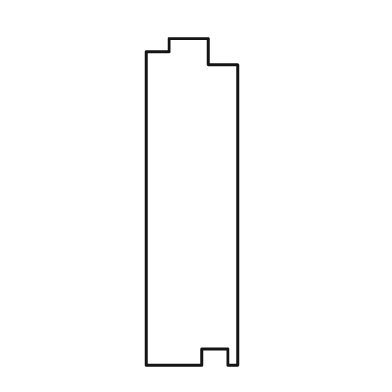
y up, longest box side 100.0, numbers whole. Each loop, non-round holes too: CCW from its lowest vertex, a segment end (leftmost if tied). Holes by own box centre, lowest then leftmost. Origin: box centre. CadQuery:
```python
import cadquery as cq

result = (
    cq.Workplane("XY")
    .moveTo(-14.0, -50.0)
    .lineTo(3.0, -50.0)
    .lineTo(3.0, -45.0)
    .lineTo(11.0, -45.0)
    .lineTo(11.0, -50.0)
    .lineTo(14.0, -50.0)
    .lineTo(14.0, 42.0)
    .lineTo(5.0, 42.0)
    .lineTo(5.0, 50.0)
    .lineTo(-7.0, 50.0)
    .lineTo(-7.0, 46.0)
    .lineTo(-14.0, 46.0)
    .close()
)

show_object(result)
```